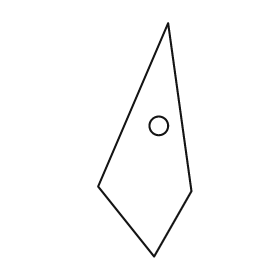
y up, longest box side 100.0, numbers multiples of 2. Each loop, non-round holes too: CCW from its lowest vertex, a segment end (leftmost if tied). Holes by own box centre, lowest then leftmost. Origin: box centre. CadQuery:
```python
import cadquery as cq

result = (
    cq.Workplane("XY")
    .moveTo(4.0, -50.0)
    .lineTo(20.0, -22.0)
    .lineTo(10.0, 50.0)
    .lineTo(-20.0, -20.0)
    .close()
    .moveTo(6.0, 6.0)
    .circle(4.0)
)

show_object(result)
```